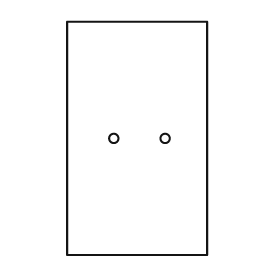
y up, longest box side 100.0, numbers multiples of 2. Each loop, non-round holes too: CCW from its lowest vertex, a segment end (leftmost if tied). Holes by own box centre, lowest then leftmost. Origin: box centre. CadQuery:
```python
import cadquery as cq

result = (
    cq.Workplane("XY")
    .moveTo(-30.0, -50.0)
    .lineTo(30.0, -50.0)
    .lineTo(30.0, 50.0)
    .lineTo(-30.0, 50.0)
    .close()
    .moveTo(-10.0, 0.0)
    .circle(2.0)
    .moveTo(12.0, 0.0)
    .circle(2.0)
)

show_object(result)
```